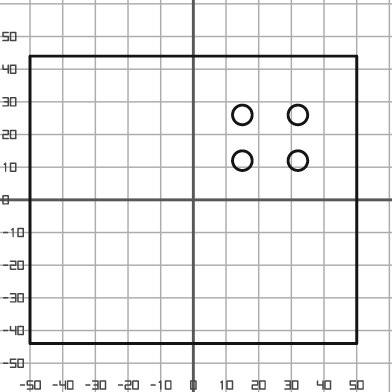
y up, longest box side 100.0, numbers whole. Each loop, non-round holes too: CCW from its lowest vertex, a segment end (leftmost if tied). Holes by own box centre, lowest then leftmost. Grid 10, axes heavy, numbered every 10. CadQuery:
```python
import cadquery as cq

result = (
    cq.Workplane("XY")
    .moveTo(-50.0, -44.0)
    .lineTo(50.0, -44.0)
    .lineTo(50.0, 44.0)
    .lineTo(-50.0, 44.0)
    .close()
    .moveTo(15.0, 12.0)
    .circle(3.0)
    .moveTo(32.0, 12.0)
    .circle(3.0)
    .moveTo(15.0, 26.0)
    .circle(3.0)
    .moveTo(32.0, 26.0)
    .circle(3.0)
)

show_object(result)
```